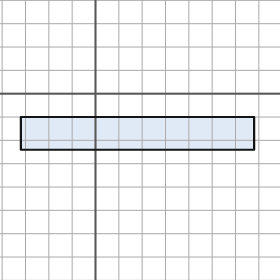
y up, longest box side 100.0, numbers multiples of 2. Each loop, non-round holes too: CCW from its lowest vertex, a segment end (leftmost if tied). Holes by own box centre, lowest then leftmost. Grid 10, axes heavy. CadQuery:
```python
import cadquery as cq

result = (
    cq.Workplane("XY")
    .moveTo(-32.0, -24.0)
    .lineTo(68.0, -24.0)
    .lineTo(68.0, -10.0)
    .lineTo(-32.0, -10.0)
    .close()
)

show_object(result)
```